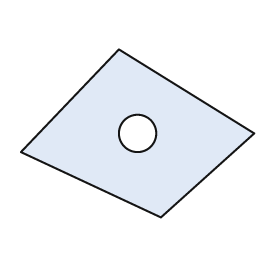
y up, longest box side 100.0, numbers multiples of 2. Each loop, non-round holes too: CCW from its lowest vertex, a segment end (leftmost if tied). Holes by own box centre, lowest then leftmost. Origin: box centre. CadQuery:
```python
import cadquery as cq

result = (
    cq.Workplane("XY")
    .moveTo(10.0, -36.0)
    .lineTo(50.0, 0.0)
    .lineTo(-8.0, 36.0)
    .lineTo(-50.0, -8.0)
    .close()
    .moveTo(0.0, 0.0)
    .circle(8.0)
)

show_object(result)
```